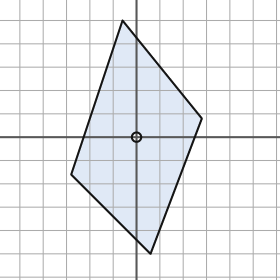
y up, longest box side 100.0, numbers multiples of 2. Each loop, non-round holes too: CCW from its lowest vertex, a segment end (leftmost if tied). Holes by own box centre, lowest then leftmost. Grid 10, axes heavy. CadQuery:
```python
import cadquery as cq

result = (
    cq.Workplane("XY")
    .moveTo(6.0, -50.0)
    .lineTo(28.0, 8.0)
    .lineTo(-6.0, 50.0)
    .lineTo(-28.0, -16.0)
    .close()
    .moveTo(0.0, 0.0)
    .circle(2.0)
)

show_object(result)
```